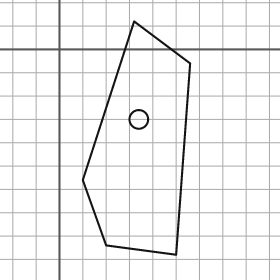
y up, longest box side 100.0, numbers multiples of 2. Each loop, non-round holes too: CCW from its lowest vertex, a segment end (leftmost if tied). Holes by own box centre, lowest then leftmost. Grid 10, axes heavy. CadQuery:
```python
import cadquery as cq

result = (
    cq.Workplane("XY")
    .moveTo(50.0, -88.0)
    .lineTo(56.0, -6.0)
    .lineTo(32.0, 12.0)
    .lineTo(10.0, -56.0)
    .lineTo(20.0, -84.0)
    .close()
    .moveTo(34.0, -30.0)
    .circle(4.0)
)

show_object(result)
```